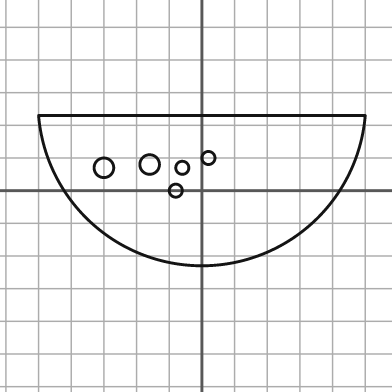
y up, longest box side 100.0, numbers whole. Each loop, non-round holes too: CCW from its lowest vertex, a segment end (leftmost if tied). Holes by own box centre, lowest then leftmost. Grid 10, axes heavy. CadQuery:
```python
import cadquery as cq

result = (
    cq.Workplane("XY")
    .moveTo(-50.0, 23.0)
    .threePointArc((0.0, -23.0), (50.0, 23.0))
    .close()
    .moveTo(-8.0, 0.0)
    .circle(2.0)
    .moveTo(-30.0, 7.0)
    .circle(3.0)
    .moveTo(-6.0, 7.0)
    .circle(2.0)
    .moveTo(-16.0, 8.0)
    .circle(3.0)
    .moveTo(2.0, 10.0)
    .circle(2.0)
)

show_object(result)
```